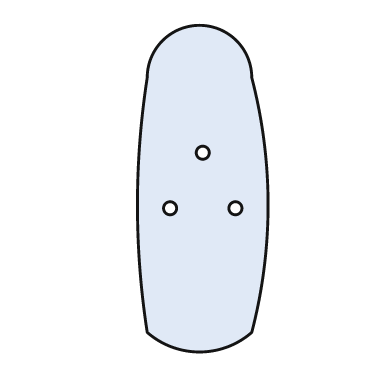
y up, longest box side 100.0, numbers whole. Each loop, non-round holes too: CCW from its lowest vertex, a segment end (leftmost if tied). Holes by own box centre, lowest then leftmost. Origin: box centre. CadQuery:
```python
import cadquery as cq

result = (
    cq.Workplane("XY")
    .moveTo(-17.0, -44.0)
    .threePointArc((-1.0, -50.0), (15.0, -44.0))
    .threePointArc((20.0, -5.0), (15.0, 34.0))
    .threePointArc((-1.0, 50.0), (-17.0, 34.0))
    .threePointArc((-20.0, -5.0), (-17.0, -44.0))
    .close()
    .moveTo(-10.0, -6.0)
    .circle(2.0)
    .moveTo(10.0, -6.0)
    .circle(2.0)
    .moveTo(0.0, 11.0)
    .circle(2.0)
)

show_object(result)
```